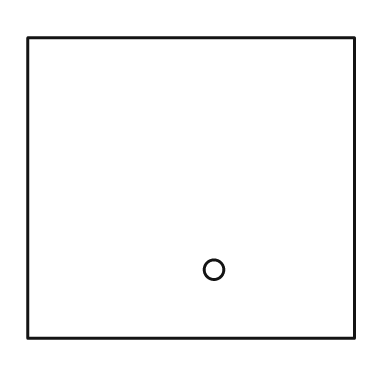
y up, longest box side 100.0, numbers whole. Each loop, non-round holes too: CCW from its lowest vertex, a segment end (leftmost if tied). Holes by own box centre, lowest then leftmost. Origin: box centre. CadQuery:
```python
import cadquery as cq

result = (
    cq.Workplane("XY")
    .moveTo(-50.0, -46.0)
    .lineTo(50.0, -46.0)
    .lineTo(50.0, 46.0)
    .lineTo(-50.0, 46.0)
    .close()
    .moveTo(7.0, -25.0)
    .circle(3.0)
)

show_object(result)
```